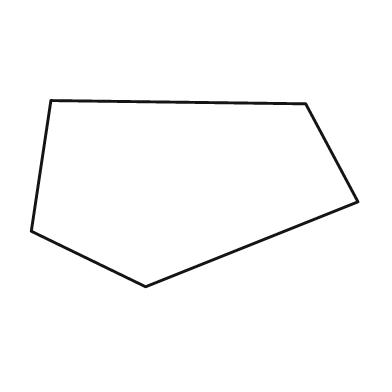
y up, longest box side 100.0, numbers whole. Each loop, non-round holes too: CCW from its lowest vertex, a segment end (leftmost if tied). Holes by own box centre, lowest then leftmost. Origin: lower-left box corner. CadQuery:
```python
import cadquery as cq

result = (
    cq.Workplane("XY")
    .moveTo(35.0, 0.0)
    .lineTo(100.0, 26.0)
    .lineTo(84.0, 56.0)
    .lineTo(6.0, 57.0)
    .lineTo(0.0, 17.0)
    .close()
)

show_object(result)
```